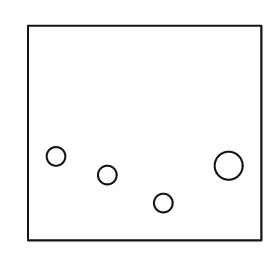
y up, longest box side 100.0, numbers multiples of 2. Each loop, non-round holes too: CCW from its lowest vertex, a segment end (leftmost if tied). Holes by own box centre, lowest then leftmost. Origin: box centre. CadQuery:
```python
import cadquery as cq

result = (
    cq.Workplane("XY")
    .moveTo(-50.0, -46.0)
    .lineTo(50.0, -46.0)
    .lineTo(50.0, 46.0)
    .lineTo(-50.0, 46.0)
    .close()
    .moveTo(8.0, -30.0)
    .circle(4.0)
    .moveTo(-16.0, -18.0)
    .circle(4.0)
    .moveTo(36.0, -14.0)
    .circle(6.0)
    .moveTo(-38.0, -10.0)
    .circle(4.0)
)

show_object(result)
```